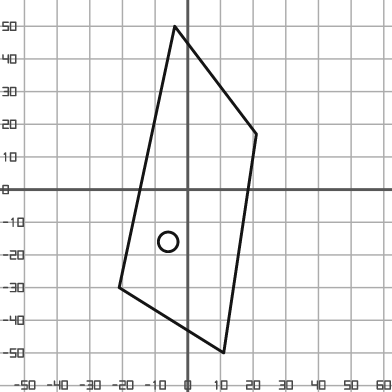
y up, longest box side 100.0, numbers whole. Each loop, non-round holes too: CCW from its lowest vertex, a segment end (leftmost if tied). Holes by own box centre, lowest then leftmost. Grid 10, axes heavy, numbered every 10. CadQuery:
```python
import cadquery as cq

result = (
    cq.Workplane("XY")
    .moveTo(11.0, -50.0)
    .lineTo(21.0, 17.0)
    .lineTo(-4.0, 50.0)
    .lineTo(-21.0, -30.0)
    .close()
    .moveTo(-6.0, -16.0)
    .circle(3.0)
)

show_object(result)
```